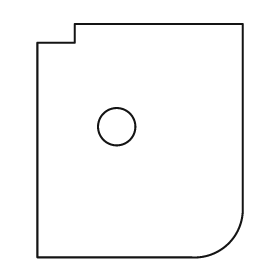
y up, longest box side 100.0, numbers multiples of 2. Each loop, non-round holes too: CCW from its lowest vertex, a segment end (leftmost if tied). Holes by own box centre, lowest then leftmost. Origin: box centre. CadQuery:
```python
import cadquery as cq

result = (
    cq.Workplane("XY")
    .moveTo(-44.0, -50.0)
    .lineTo(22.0, -50.0)
    .threePointArc((38.0, -44.0), (44.0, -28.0))
    .lineTo(44.0, 50.0)
    .lineTo(-28.0, 50.0)
    .lineTo(-28.0, 42.0)
    .lineTo(-44.0, 42.0)
    .close()
    .moveTo(-10.0, 6.0)
    .circle(8.0)
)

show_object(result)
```